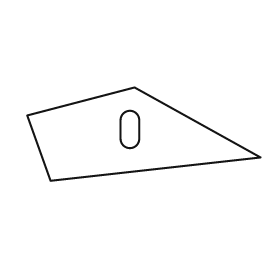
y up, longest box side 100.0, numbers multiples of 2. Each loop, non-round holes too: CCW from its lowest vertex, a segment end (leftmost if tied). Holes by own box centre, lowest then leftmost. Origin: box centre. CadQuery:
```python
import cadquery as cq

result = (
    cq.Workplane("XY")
    .moveTo(-40.0, -20.0)
    .lineTo(50.0, -10.0)
    .lineTo(-4.0, 20.0)
    .lineTo(-50.0, 8.0)
    .close()
    .moveTo(-10.0, -2.0)
    .threePointArc((-6.0, -6.0), (-2.0, -2.0))
    .lineTo(-2.0, 6.0)
    .threePointArc((-6.0, 10.0), (-10.0, 6.0))
    .close()
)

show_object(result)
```